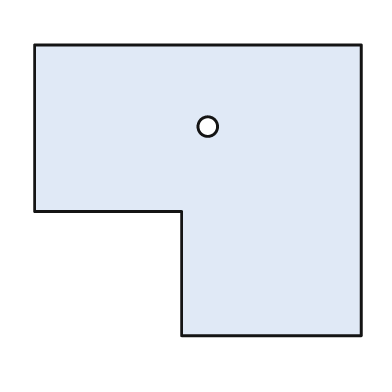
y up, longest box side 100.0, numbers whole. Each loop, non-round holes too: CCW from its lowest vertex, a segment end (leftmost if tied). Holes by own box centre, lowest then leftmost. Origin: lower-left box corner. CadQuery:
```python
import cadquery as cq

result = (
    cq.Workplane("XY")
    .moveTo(45.0, 0.0)
    .lineTo(100.0, 0.0)
    .lineTo(100.0, 89.0)
    .lineTo(0.0, 89.0)
    .lineTo(0.0, 38.0)
    .lineTo(45.0, 38.0)
    .close()
    .moveTo(53.0, 64.0)
    .circle(3.0)
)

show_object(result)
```